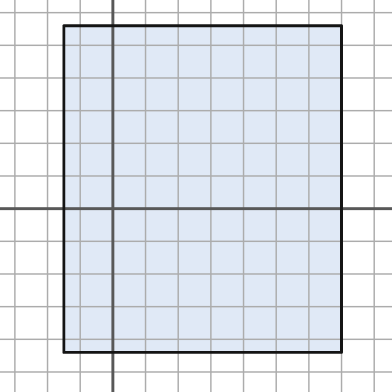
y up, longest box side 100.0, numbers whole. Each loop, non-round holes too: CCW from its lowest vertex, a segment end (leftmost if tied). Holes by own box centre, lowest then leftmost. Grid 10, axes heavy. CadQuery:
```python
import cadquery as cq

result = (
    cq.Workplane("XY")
    .moveTo(-15.0, -44.0)
    .lineTo(70.0, -44.0)
    .lineTo(70.0, 56.0)
    .lineTo(-15.0, 56.0)
    .close()
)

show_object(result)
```